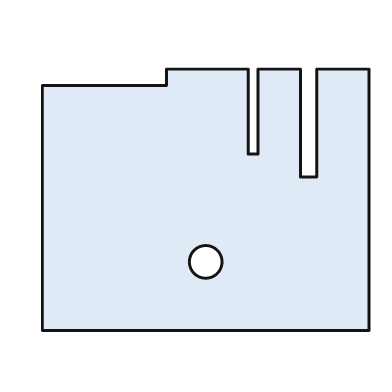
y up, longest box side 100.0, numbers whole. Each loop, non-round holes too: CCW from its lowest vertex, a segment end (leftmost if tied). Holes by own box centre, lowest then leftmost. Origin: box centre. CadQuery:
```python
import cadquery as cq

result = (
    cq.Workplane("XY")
    .moveTo(-50.0, -40.0)
    .lineTo(50.0, -40.0)
    .lineTo(50.0, 40.0)
    .lineTo(34.0, 40.0)
    .lineTo(34.0, 7.0)
    .lineTo(29.0, 7.0)
    .lineTo(29.0, 40.0)
    .lineTo(16.0, 40.0)
    .lineTo(16.0, 14.0)
    .lineTo(13.0, 14.0)
    .lineTo(13.0, 40.0)
    .lineTo(-12.0, 40.0)
    .lineTo(-12.0, 35.0)
    .lineTo(-50.0, 35.0)
    .close()
    .moveTo(0.0, -19.0)
    .circle(5.0)
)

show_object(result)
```